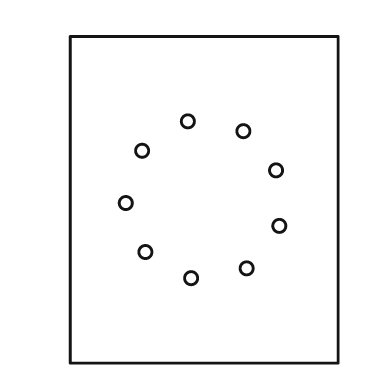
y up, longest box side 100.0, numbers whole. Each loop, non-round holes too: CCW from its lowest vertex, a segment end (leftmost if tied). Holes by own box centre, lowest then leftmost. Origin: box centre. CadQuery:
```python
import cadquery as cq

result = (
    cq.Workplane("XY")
    .moveTo(-41.0, -50.0)
    .lineTo(41.0, -50.0)
    .lineTo(41.0, 50.0)
    .lineTo(-41.0, 50.0)
    .close()
    .moveTo(-4.0, -24.0)
    .circle(2.0)
    .moveTo(13.0, -21.0)
    .circle(2.0)
    .moveTo(-18.0, -16.0)
    .circle(2.0)
    .moveTo(23.0, -8.0)
    .circle(2.0)
    .moveTo(-24.0, -1.0)
    .circle(2.0)
    .moveTo(22.0, 9.0)
    .circle(2.0)
    .moveTo(-19.0, 15.0)
    .circle(2.0)
    .moveTo(12.0, 21.0)
    .circle(2.0)
    .moveTo(-5.0, 24.0)
    .circle(2.0)
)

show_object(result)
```